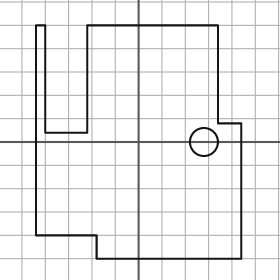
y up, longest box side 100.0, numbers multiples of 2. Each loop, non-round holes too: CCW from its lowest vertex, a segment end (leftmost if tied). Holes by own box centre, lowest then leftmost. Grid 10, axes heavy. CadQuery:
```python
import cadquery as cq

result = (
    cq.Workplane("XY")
    .moveTo(-18.0, -50.0)
    .lineTo(44.0, -50.0)
    .lineTo(44.0, 8.0)
    .lineTo(34.0, 8.0)
    .lineTo(34.0, 50.0)
    .lineTo(-22.0, 50.0)
    .lineTo(-22.0, 4.0)
    .lineTo(-40.0, 4.0)
    .lineTo(-40.0, 50.0)
    .lineTo(-44.0, 50.0)
    .lineTo(-44.0, -40.0)
    .lineTo(-18.0, -40.0)
    .close()
    .moveTo(28.0, 0.0)
    .circle(6.0)
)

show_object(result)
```